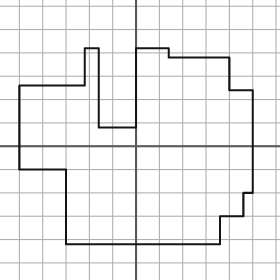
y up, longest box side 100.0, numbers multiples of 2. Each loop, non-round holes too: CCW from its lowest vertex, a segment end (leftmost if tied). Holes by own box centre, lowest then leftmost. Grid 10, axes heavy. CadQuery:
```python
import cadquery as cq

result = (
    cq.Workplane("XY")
    .moveTo(-30.0, -42.0)
    .lineTo(36.0, -42.0)
    .lineTo(36.0, -30.0)
    .lineTo(46.0, -30.0)
    .lineTo(46.0, -20.0)
    .lineTo(50.0, -20.0)
    .lineTo(50.0, 24.0)
    .lineTo(40.0, 24.0)
    .lineTo(40.0, 38.0)
    .lineTo(14.0, 38.0)
    .lineTo(14.0, 42.0)
    .lineTo(0.0, 42.0)
    .lineTo(0.0, 8.0)
    .lineTo(-16.0, 8.0)
    .lineTo(-16.0, 42.0)
    .lineTo(-22.0, 42.0)
    .lineTo(-22.0, 26.0)
    .lineTo(-50.0, 26.0)
    .lineTo(-50.0, -10.0)
    .lineTo(-30.0, -10.0)
    .close()
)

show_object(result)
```